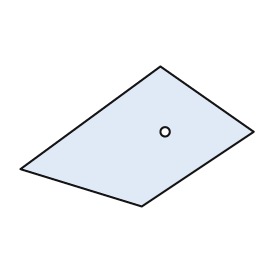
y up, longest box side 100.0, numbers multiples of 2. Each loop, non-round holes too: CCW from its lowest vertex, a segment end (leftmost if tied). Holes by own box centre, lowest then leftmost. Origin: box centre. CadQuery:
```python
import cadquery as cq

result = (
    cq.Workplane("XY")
    .moveTo(2.0, -30.0)
    .lineTo(50.0, 2.0)
    .lineTo(10.0, 30.0)
    .lineTo(-50.0, -14.0)
    .close()
    .moveTo(12.0, 2.0)
    .circle(2.0)
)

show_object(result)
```